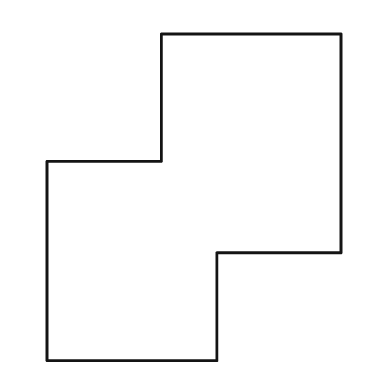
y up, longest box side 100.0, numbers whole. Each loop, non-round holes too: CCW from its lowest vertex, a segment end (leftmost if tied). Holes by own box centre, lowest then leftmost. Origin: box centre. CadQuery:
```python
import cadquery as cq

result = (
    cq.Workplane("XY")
    .moveTo(-45.0, -50.0)
    .lineTo(7.0, -50.0)
    .lineTo(7.0, -17.0)
    .lineTo(45.0, -17.0)
    .lineTo(45.0, 50.0)
    .lineTo(-10.0, 50.0)
    .lineTo(-10.0, 11.0)
    .lineTo(-45.0, 11.0)
    .close()
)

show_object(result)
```